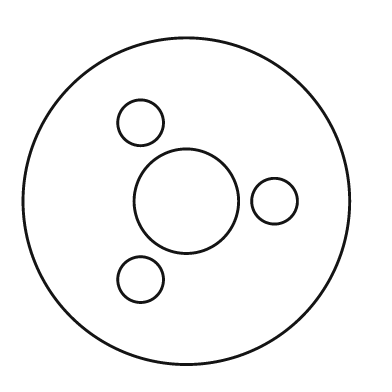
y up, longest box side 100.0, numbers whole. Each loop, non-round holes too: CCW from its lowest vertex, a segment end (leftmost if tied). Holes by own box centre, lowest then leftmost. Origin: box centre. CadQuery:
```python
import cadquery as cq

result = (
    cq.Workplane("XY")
    .moveTo(0.0, 0.0)
    .circle(50.0)
    .moveTo(-14.0, -24.0)
    .circle(7.0)
    .moveTo(0.0, 0.0)
    .circle(16.0)
    .moveTo(27.0, 0.0)
    .circle(7.0)
    .moveTo(-14.0, 24.0)
    .circle(7.0)
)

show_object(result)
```